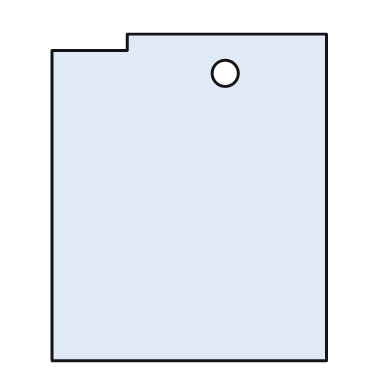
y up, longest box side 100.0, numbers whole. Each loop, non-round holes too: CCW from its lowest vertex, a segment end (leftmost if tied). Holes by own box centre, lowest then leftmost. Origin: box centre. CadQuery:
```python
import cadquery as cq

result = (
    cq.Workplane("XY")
    .moveTo(-42.0, -50.0)
    .lineTo(42.0, -50.0)
    .lineTo(42.0, 50.0)
    .lineTo(-19.0, 50.0)
    .lineTo(-19.0, 45.0)
    .lineTo(-42.0, 45.0)
    .close()
    .moveTo(11.0, 38.0)
    .circle(4.0)
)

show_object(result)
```